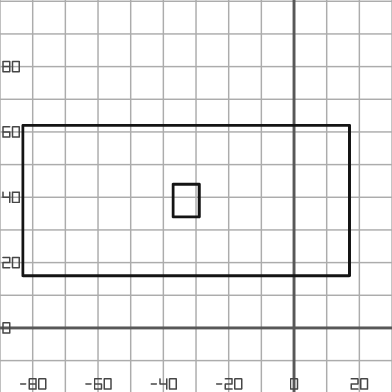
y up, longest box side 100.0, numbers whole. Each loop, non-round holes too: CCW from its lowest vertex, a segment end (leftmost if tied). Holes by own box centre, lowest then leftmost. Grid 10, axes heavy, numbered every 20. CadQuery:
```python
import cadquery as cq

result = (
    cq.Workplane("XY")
    .moveTo(-83.0, 16.0)
    .lineTo(17.0, 16.0)
    .lineTo(17.0, 62.0)
    .lineTo(-83.0, 62.0)
    .close()
    .moveTo(-37.0, 34.0)
    .lineTo(-29.0, 34.0)
    .lineTo(-29.0, 44.0)
    .lineTo(-37.0, 44.0)
    .close()
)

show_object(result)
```